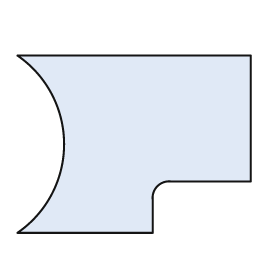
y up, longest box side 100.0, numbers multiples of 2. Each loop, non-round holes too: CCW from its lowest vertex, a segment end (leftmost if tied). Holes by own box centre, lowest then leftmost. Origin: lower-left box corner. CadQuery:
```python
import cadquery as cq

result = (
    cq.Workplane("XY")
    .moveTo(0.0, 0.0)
    .lineTo(58.0, 0.0)
    .lineTo(58.0, 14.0)
    .threePointArc((60.0, 20.0), (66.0, 22.0))
    .lineTo(100.0, 22.0)
    .lineTo(100.0, 76.0)
    .lineTo(0.0, 76.0)
    .threePointArc((20.0, 38.0), (0.0, 0.0))
    .close()
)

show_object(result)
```